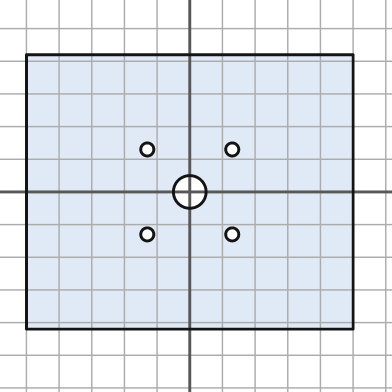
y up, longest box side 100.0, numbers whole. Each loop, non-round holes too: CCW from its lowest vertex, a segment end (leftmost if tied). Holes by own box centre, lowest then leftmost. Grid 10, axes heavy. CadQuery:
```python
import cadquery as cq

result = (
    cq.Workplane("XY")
    .moveTo(-50.0, -42.0)
    .lineTo(50.0, -42.0)
    .lineTo(50.0, 42.0)
    .lineTo(-50.0, 42.0)
    .close()
    .moveTo(-13.0, -13.0)
    .circle(2.0)
    .moveTo(13.0, -13.0)
    .circle(2.0)
    .moveTo(0.0, 0.0)
    .circle(5.0)
    .moveTo(-13.0, 13.0)
    .circle(2.0)
    .moveTo(13.0, 13.0)
    .circle(2.0)
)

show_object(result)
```